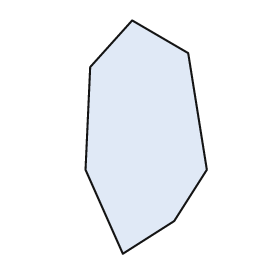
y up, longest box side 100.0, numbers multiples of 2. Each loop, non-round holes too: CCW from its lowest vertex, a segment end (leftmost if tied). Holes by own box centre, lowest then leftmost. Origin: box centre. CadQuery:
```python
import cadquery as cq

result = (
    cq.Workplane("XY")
    .moveTo(-10.0, -50.0)
    .lineTo(12.0, -36.0)
    .lineTo(26.0, -14.0)
    .lineTo(18.0, 36.0)
    .lineTo(-6.0, 50.0)
    .lineTo(-24.0, 30.0)
    .lineTo(-26.0, -14.0)
    .close()
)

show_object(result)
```